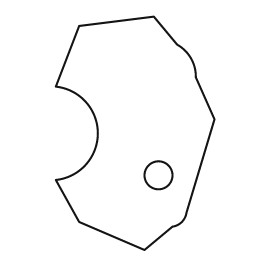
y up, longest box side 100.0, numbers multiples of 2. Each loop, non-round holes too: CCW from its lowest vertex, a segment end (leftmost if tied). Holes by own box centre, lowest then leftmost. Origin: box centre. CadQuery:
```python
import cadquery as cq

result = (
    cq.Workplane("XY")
    .moveTo(4.0, -50.0)
    .lineTo(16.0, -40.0)
    .threePointArc((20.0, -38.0), (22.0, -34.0))
    .lineTo(34.0, 6.0)
    .lineTo(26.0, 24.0)
    .threePointArc((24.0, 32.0), (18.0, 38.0))
    .lineTo(8.0, 50.0)
    .lineTo(-24.0, 46.0)
    .lineTo(-34.0, 20.0)
    .threePointArc((-16.0, 0.0), (-34.0, -20.0))
    .lineTo(-24.0, -38.0)
    .close()
    .moveTo(10.0, -18.0)
    .circle(6.0)
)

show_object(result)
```